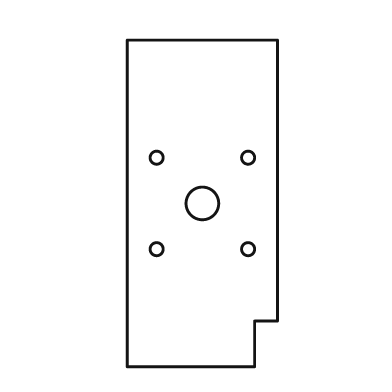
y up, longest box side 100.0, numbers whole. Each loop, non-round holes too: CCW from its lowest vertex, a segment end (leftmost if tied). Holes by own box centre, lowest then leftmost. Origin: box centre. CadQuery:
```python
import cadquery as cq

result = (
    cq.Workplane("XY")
    .moveTo(-23.0, -50.0)
    .lineTo(16.0, -50.0)
    .lineTo(16.0, -36.0)
    .lineTo(23.0, -36.0)
    .lineTo(23.0, 50.0)
    .lineTo(-23.0, 50.0)
    .close()
    .moveTo(-14.0, -14.0)
    .circle(2.0)
    .moveTo(14.0, -14.0)
    .circle(2.0)
    .moveTo(0.0, 0.0)
    .circle(5.0)
    .moveTo(-14.0, 14.0)
    .circle(2.0)
    .moveTo(14.0, 14.0)
    .circle(2.0)
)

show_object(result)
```